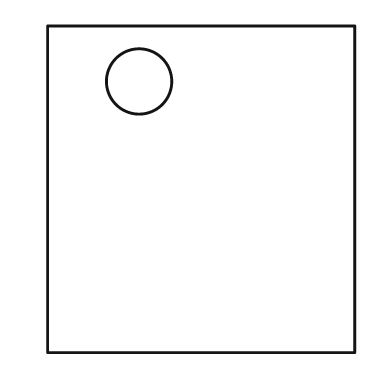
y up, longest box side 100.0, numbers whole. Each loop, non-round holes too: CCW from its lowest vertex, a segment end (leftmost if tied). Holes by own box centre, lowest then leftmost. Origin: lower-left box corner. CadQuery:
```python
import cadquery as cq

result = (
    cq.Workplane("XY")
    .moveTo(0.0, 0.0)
    .lineTo(94.0, 0.0)
    .lineTo(94.0, 100.0)
    .lineTo(0.0, 100.0)
    .close()
    .moveTo(28.0, 83.0)
    .circle(10.0)
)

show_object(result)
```